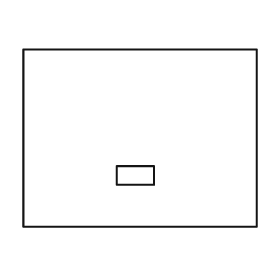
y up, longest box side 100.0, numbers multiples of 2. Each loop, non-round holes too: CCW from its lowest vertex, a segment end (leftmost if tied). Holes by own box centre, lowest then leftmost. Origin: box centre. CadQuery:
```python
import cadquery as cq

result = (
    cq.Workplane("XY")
    .moveTo(-50.0, -38.0)
    .lineTo(50.0, -38.0)
    .lineTo(50.0, 38.0)
    .lineTo(-50.0, 38.0)
    .close()
    .moveTo(-10.0, -20.0)
    .lineTo(6.0, -20.0)
    .lineTo(6.0, -12.0)
    .lineTo(-10.0, -12.0)
    .close()
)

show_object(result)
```